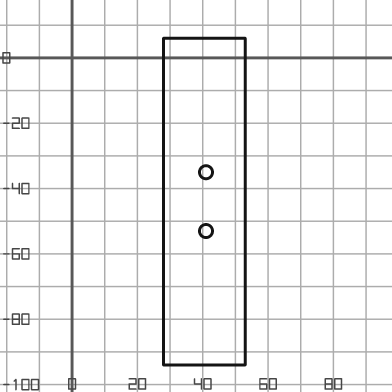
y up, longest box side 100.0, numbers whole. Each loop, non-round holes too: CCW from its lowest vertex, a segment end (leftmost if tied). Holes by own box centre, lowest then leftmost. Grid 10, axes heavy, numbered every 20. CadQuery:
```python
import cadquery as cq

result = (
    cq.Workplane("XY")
    .moveTo(28.0, -94.0)
    .lineTo(53.0, -94.0)
    .lineTo(53.0, 6.0)
    .lineTo(28.0, 6.0)
    .close()
    .moveTo(41.0, -53.0)
    .circle(2.0)
    .moveTo(41.0, -35.0)
    .circle(2.0)
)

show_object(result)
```